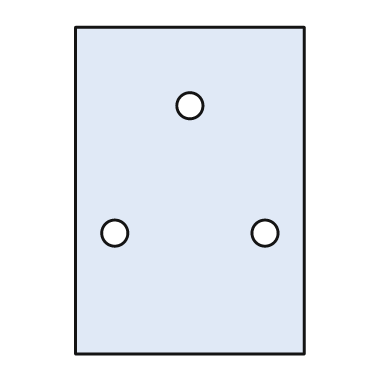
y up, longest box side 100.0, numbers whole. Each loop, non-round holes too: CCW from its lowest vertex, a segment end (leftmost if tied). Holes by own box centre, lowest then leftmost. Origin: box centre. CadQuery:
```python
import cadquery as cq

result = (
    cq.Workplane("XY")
    .moveTo(-35.0, -50.0)
    .lineTo(35.0, -50.0)
    .lineTo(35.0, 50.0)
    .lineTo(-35.0, 50.0)
    .close()
    .moveTo(-23.0, -13.0)
    .circle(4.0)
    .moveTo(23.0, -13.0)
    .circle(4.0)
    .moveTo(0.0, 26.0)
    .circle(4.0)
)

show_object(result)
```